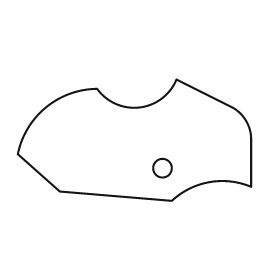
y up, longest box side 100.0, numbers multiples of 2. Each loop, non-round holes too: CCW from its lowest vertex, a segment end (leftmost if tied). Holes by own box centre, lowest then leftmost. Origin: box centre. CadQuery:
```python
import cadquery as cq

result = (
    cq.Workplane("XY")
    .moveTo(16.0, -26.0)
    .threePointArc((32.0, -18.0), (50.0, -20.0))
    .lineTo(50.0, 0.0)
    .threePointArc((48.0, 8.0), (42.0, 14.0))
    .lineTo(18.0, 26.0)
    .threePointArc((2.0, 14.0), (-16.0, 22.0))
    .threePointArc((-38.0, 14.0), (-50.0, -6.0))
    .lineTo(-32.0, -22.0)
    .close()
    .moveTo(12.0, -12.0)
    .circle(4.0)
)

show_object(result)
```